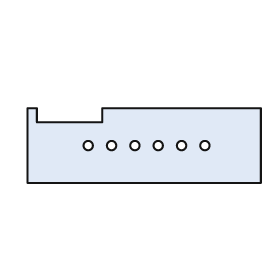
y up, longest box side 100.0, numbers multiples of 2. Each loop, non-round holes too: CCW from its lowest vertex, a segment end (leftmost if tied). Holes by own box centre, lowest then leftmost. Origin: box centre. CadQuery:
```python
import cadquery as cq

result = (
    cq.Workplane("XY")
    .moveTo(-50.0, -16.0)
    .lineTo(50.0, -16.0)
    .lineTo(50.0, 16.0)
    .lineTo(-18.0, 16.0)
    .lineTo(-18.0, 10.0)
    .lineTo(-46.0, 10.0)
    .lineTo(-46.0, 16.0)
    .lineTo(-50.0, 16.0)
    .close()
    .moveTo(-24.0, 0.0)
    .circle(2.0)
    .moveTo(-14.0, 0.0)
    .circle(2.0)
    .moveTo(-4.0, 0.0)
    .circle(2.0)
    .moveTo(6.0, 0.0)
    .circle(2.0)
    .moveTo(16.0, 0.0)
    .circle(2.0)
    .moveTo(26.0, 0.0)
    .circle(2.0)
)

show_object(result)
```